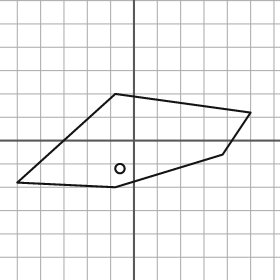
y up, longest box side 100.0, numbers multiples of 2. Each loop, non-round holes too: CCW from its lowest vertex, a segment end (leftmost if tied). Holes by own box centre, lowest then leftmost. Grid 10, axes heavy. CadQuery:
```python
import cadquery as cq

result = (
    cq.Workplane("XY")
    .moveTo(-8.0, -20.0)
    .lineTo(38.0, -6.0)
    .lineTo(50.0, 12.0)
    .lineTo(-8.0, 20.0)
    .lineTo(-50.0, -18.0)
    .close()
    .moveTo(-6.0, -12.0)
    .circle(2.0)
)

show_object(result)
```